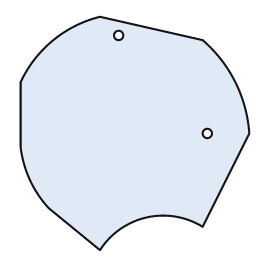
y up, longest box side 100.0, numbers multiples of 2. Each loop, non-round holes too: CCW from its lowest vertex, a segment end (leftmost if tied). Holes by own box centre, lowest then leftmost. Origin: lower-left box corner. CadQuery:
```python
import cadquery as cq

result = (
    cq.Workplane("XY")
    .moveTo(34.0, 0.0)
    .threePointArc((54.0, 14.0), (78.0, 10.0))
    .lineTo(98.0, 50.0)
    .threePointArc((92.0, 72.0), (78.0, 90.0))
    .lineTo(34.0, 100.0)
    .threePointArc((14.0, 90.0), (0.0, 72.0))
    .lineTo(0.0, 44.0)
    .threePointArc((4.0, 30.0), (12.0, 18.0))
    .close()
    .moveTo(80.0, 50.0)
    .circle(2.0)
    .moveTo(42.0, 92.0)
    .circle(2.0)
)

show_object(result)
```